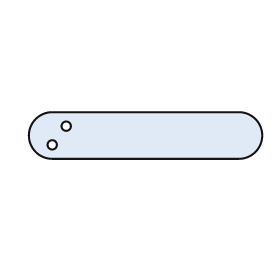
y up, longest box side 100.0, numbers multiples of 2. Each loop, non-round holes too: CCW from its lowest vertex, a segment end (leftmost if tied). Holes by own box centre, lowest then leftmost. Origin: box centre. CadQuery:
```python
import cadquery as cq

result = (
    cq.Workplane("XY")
    .moveTo(-40.0, -10.0)
    .lineTo(40.0, -10.0)
    .threePointArc((50.0, 0.0), (40.0, 10.0))
    .lineTo(-40.0, 10.0)
    .threePointArc((-50.0, 0.0), (-40.0, -10.0))
    .close()
    .moveTo(-40.0, -4.0)
    .circle(2.0)
    .moveTo(-34.0, 4.0)
    .circle(2.0)
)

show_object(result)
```